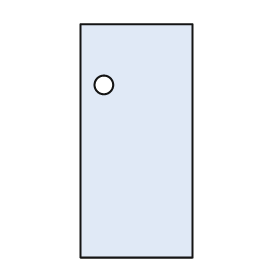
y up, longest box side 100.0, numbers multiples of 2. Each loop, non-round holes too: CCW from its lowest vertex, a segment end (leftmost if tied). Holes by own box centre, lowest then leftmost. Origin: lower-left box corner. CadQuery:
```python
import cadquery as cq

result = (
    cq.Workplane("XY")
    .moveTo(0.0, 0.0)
    .lineTo(48.0, 0.0)
    .lineTo(48.0, 100.0)
    .lineTo(0.0, 100.0)
    .close()
    .moveTo(10.0, 74.0)
    .circle(4.0)
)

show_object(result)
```